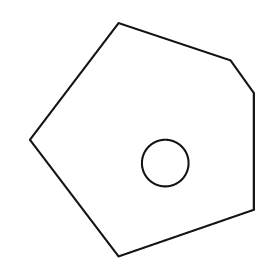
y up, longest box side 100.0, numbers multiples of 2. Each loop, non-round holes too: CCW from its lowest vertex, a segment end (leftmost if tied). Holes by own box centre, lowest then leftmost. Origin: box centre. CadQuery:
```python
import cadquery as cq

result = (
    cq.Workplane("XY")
    .moveTo(-10.0, -50.0)
    .lineTo(48.0, -30.0)
    .lineTo(48.0, 20.0)
    .lineTo(38.0, 34.0)
    .lineTo(-10.0, 50.0)
    .lineTo(-48.0, 0.0)
    .close()
    .moveTo(10.0, -10.0)
    .circle(10.0)
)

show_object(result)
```